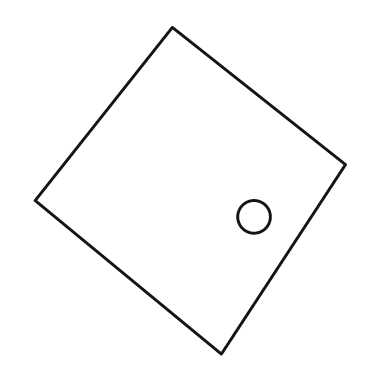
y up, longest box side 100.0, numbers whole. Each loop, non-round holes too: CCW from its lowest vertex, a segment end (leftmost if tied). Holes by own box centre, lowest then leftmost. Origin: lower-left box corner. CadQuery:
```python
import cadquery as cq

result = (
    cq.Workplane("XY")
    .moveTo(57.0, 0.0)
    .lineTo(95.0, 58.0)
    .lineTo(42.0, 100.0)
    .lineTo(0.0, 47.0)
    .close()
    .moveTo(67.0, 42.0)
    .circle(5.0)
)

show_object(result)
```